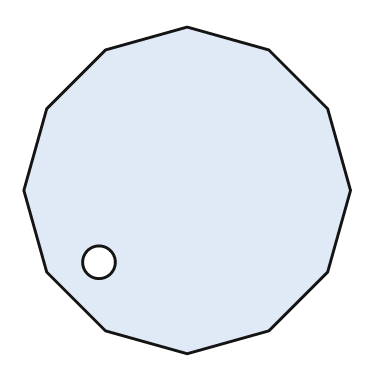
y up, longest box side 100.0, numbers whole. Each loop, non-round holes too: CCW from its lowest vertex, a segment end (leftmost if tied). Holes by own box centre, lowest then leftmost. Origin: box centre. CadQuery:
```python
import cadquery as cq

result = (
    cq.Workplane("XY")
    .moveTo(0.0, -50.0)
    .lineTo(25.0, -43.0)
    .lineTo(43.0, -25.0)
    .lineTo(50.0, 0.0)
    .lineTo(43.0, 25.0)
    .lineTo(25.0, 43.0)
    .lineTo(0.0, 50.0)
    .lineTo(-25.0, 43.0)
    .lineTo(-43.0, 25.0)
    .lineTo(-50.0, 0.0)
    .lineTo(-43.0, -25.0)
    .lineTo(-25.0, -43.0)
    .close()
    .moveTo(-27.0, -22.0)
    .circle(5.0)
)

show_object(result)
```